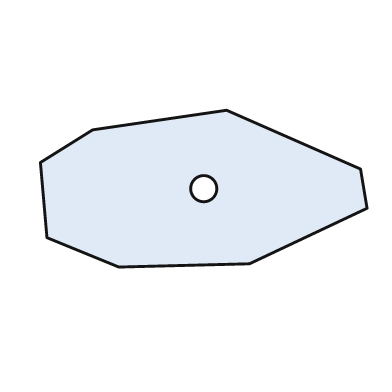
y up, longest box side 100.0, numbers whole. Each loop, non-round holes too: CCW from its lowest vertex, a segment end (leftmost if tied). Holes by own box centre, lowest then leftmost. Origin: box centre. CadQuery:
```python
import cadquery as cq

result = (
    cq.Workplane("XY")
    .moveTo(-26.0, -24.0)
    .lineTo(14.0, -23.0)
    .lineTo(50.0, -6.0)
    .lineTo(48.0, 6.0)
    .lineTo(7.0, 24.0)
    .lineTo(-34.0, 18.0)
    .lineTo(-50.0, 8.0)
    .lineTo(-48.0, -15.0)
    .close()
    .moveTo(0.0, 0.0)
    .circle(4.0)
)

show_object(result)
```